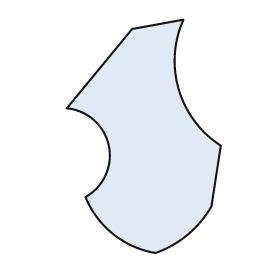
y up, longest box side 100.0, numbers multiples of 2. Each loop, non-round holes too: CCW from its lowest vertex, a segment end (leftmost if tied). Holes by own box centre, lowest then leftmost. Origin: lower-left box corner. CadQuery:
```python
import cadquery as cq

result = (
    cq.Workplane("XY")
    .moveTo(38.0, 0.0)
    .threePointArc((52.0, 8.0), (62.0, 20.0))
    .lineTo(66.0, 46.0)
    .threePointArc((48.0, 70.0), (50.0, 100.0))
    .lineTo(28.0, 96.0)
    .lineTo(0.0, 62.0)
    .threePointArc((18.0, 46.0), (8.0, 24.0))
    .threePointArc((20.0, 8.0), (38.0, 0.0))
    .close()
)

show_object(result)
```